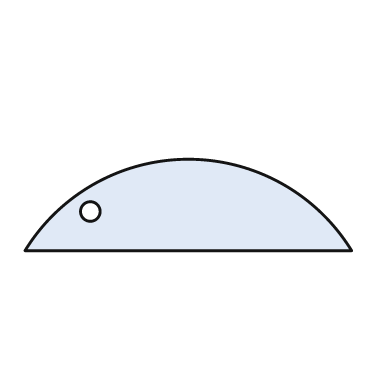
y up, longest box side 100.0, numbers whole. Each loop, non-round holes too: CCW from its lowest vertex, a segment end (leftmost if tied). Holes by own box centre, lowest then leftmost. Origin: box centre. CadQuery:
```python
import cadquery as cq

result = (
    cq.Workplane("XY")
    .moveTo(-50.0, -14.0)
    .lineTo(50.0, -14.0)
    .threePointArc((0.0, 14.0), (-50.0, -14.0))
    .close()
    .moveTo(-30.0, -2.0)
    .circle(3.0)
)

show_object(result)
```